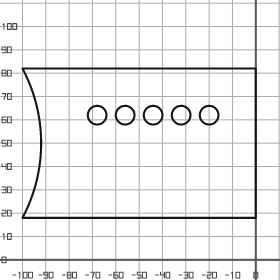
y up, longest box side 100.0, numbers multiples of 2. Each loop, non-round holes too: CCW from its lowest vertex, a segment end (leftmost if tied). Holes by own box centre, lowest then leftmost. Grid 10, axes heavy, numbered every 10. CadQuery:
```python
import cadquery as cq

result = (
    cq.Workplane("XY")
    .moveTo(-100.0, 18.0)
    .lineTo(0.0, 18.0)
    .lineTo(0.0, 82.0)
    .lineTo(-100.0, 82.0)
    .threePointArc((-92.0, 50.0), (-100.0, 18.0))
    .close()
    .moveTo(-68.0, 62.0)
    .circle(4.0)
    .moveTo(-56.0, 62.0)
    .circle(4.0)
    .moveTo(-44.0, 62.0)
    .circle(4.0)
    .moveTo(-32.0, 62.0)
    .circle(4.0)
    .moveTo(-20.0, 62.0)
    .circle(4.0)
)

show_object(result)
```